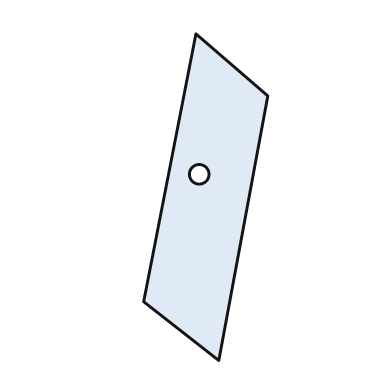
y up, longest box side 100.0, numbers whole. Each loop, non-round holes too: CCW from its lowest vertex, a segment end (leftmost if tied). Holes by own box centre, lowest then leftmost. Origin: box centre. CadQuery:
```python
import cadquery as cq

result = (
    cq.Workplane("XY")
    .moveTo(4.0, -50.0)
    .lineTo(19.0, 31.0)
    .lineTo(-3.0, 50.0)
    .lineTo(-19.0, -32.0)
    .close()
    .moveTo(-2.0, 7.0)
    .circle(3.0)
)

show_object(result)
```